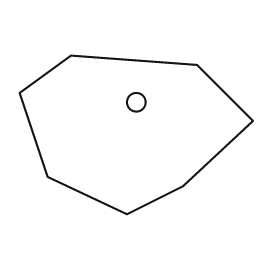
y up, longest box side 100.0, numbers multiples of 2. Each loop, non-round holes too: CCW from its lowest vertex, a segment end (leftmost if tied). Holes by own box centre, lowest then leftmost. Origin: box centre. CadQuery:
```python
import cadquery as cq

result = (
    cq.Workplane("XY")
    .moveTo(-4.0, -34.0)
    .lineTo(20.0, -22.0)
    .lineTo(50.0, 6.0)
    .lineTo(26.0, 30.0)
    .lineTo(-28.0, 34.0)
    .lineTo(-50.0, 18.0)
    .lineTo(-38.0, -18.0)
    .close()
    .moveTo(0.0, 14.0)
    .circle(4.0)
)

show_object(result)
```